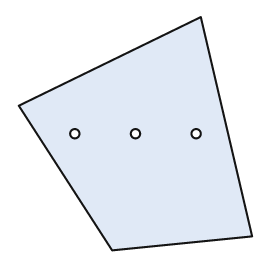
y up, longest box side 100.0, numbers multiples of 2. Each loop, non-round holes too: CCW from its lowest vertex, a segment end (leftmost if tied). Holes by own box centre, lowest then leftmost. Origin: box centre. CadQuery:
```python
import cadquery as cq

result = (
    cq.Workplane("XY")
    .moveTo(-10.0, -50.0)
    .lineTo(50.0, -44.0)
    .lineTo(28.0, 50.0)
    .lineTo(-50.0, 12.0)
    .close()
    .moveTo(-26.0, 0.0)
    .circle(2.0)
    .moveTo(0.0, 0.0)
    .circle(2.0)
    .moveTo(26.0, 0.0)
    .circle(2.0)
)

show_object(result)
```